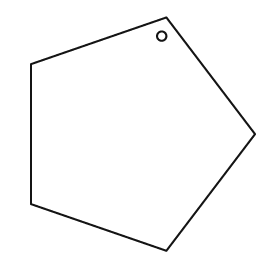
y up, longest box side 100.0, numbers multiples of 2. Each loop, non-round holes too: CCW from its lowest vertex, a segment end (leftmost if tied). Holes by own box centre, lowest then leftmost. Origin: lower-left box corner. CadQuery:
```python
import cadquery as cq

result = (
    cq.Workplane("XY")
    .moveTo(58.0, 0.0)
    .lineTo(96.0, 50.0)
    .lineTo(58.0, 100.0)
    .lineTo(0.0, 80.0)
    .lineTo(0.0, 20.0)
    .close()
    .moveTo(56.0, 92.0)
    .circle(2.0)
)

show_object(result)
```